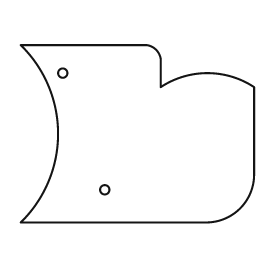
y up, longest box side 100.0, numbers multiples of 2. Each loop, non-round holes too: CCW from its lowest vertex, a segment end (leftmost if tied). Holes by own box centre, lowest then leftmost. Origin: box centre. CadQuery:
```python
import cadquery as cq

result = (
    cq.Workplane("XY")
    .moveTo(-50.0, -38.0)
    .lineTo(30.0, -38.0)
    .threePointArc((44.0, -32.0), (50.0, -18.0))
    .lineTo(50.0, 20.0)
    .threePointArc((30.0, 26.0), (10.0, 20.0))
    .lineTo(10.0, 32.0)
    .threePointArc((8.0, 36.0), (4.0, 38.0))
    .lineTo(-50.0, 38.0)
    .threePointArc((-34.0, 0.0), (-50.0, -38.0))
    .close()
    .moveTo(-14.0, -24.0)
    .circle(2.0)
    .moveTo(-32.0, 26.0)
    .circle(2.0)
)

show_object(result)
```